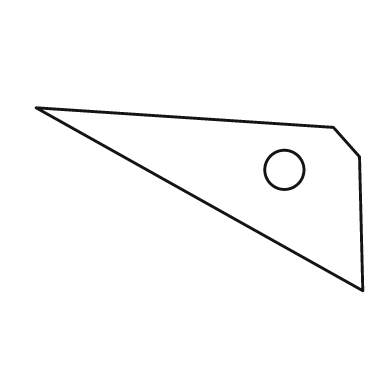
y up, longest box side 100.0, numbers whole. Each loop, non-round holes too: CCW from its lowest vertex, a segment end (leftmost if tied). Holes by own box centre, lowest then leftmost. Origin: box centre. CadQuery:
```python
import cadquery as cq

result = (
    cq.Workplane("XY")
    .moveTo(50.0, -28.0)
    .lineTo(49.0, 13.0)
    .lineTo(41.0, 22.0)
    .lineTo(-50.0, 28.0)
    .close()
    .moveTo(26.0, 9.0)
    .circle(6.0)
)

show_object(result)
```